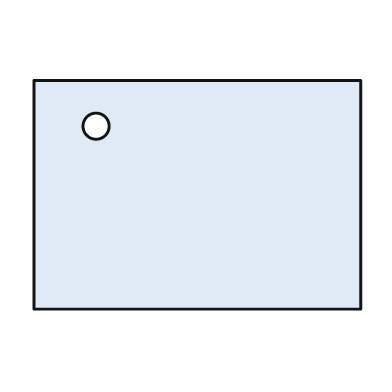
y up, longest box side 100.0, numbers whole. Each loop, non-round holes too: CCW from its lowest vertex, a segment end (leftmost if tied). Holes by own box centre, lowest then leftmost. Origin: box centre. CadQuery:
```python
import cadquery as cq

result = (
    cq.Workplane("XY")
    .moveTo(-50.0, -35.0)
    .lineTo(50.0, -35.0)
    .lineTo(50.0, 35.0)
    .lineTo(-50.0, 35.0)
    .close()
    .moveTo(-31.0, 21.0)
    .circle(4.0)
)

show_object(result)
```